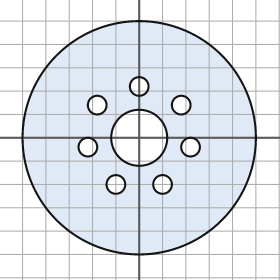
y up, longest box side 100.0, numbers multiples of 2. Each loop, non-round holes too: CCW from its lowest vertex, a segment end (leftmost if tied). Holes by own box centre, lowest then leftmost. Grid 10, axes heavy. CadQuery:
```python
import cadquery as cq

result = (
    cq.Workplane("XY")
    .moveTo(0.0, 0.0)
    .circle(50.0)
    .moveTo(-10.0, -20.0)
    .circle(4.0)
    .moveTo(10.0, -20.0)
    .circle(4.0)
    .moveTo(-22.0, -4.0)
    .circle(4.0)
    .moveTo(22.0, -4.0)
    .circle(4.0)
    .moveTo(0.0, 0.0)
    .circle(12.0)
    .moveTo(-18.0, 14.0)
    .circle(4.0)
    .moveTo(18.0, 14.0)
    .circle(4.0)
    .moveTo(0.0, 22.0)
    .circle(4.0)
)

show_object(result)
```